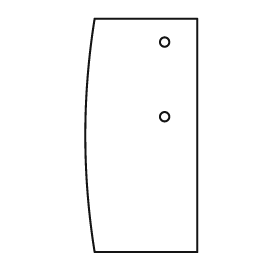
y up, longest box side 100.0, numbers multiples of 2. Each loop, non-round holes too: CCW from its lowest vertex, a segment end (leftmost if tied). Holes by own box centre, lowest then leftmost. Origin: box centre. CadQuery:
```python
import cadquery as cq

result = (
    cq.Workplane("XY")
    .moveTo(-20.0, -50.0)
    .lineTo(24.0, -50.0)
    .lineTo(24.0, 50.0)
    .lineTo(-20.0, 50.0)
    .threePointArc((-24.0, 0.0), (-20.0, -50.0))
    .close()
    .moveTo(10.0, 8.0)
    .circle(2.0)
    .moveTo(10.0, 40.0)
    .circle(2.0)
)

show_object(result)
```